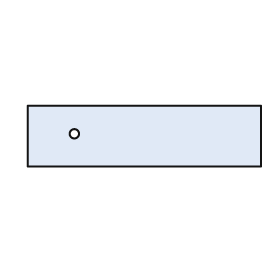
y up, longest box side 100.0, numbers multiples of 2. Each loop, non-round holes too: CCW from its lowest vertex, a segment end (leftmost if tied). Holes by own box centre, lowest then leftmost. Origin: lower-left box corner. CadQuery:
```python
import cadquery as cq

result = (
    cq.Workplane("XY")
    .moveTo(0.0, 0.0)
    .lineTo(100.0, 0.0)
    .lineTo(100.0, 26.0)
    .lineTo(0.0, 26.0)
    .close()
    .moveTo(20.0, 14.0)
    .circle(2.0)
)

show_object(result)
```